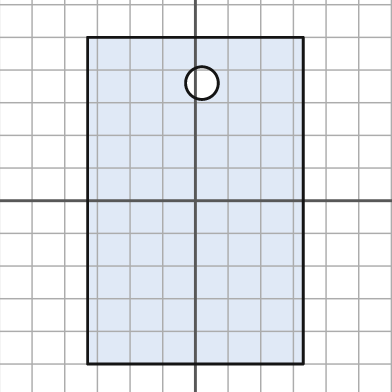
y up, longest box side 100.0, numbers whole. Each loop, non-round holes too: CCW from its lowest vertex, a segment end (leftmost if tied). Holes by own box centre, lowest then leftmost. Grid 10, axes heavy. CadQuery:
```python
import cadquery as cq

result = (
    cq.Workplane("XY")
    .moveTo(-33.0, -50.0)
    .lineTo(33.0, -50.0)
    .lineTo(33.0, 50.0)
    .lineTo(-33.0, 50.0)
    .close()
    .moveTo(2.0, 36.0)
    .circle(5.0)
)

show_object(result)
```